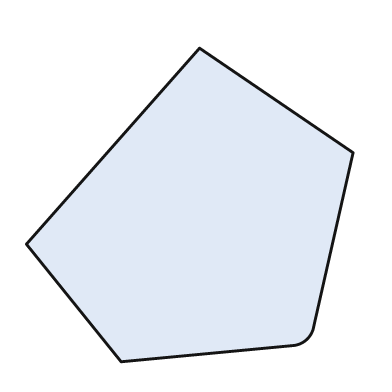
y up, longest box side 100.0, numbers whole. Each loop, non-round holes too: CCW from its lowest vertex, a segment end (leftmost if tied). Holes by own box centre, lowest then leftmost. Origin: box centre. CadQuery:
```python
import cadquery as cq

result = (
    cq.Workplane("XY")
    .moveTo(-21.0, -48.0)
    .lineTo(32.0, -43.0)
    .threePointArc((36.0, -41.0), (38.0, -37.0))
    .lineTo(50.0, 16.0)
    .lineTo(3.0, 48.0)
    .lineTo(-50.0, -12.0)
    .close()
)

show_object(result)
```